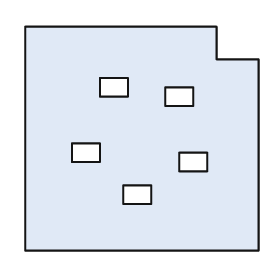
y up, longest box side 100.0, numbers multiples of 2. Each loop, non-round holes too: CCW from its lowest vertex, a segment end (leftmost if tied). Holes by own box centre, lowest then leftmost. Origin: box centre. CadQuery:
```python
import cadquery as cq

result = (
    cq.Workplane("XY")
    .moveTo(-50.0, -48.0)
    .lineTo(50.0, -48.0)
    .lineTo(50.0, 34.0)
    .lineTo(32.0, 34.0)
    .lineTo(32.0, 48.0)
    .lineTo(-50.0, 48.0)
    .close()
    .moveTo(-8.0, -28.0)
    .lineTo(4.0, -28.0)
    .lineTo(4.0, -20.0)
    .lineTo(-8.0, -20.0)
    .close()
    .moveTo(16.0, -14.0)
    .lineTo(28.0, -14.0)
    .lineTo(28.0, -6.0)
    .lineTo(16.0, -6.0)
    .close()
    .moveTo(-30.0, -10.0)
    .lineTo(-18.0, -10.0)
    .lineTo(-18.0, -2.0)
    .lineTo(-30.0, -2.0)
    .close()
    .moveTo(10.0, 14.0)
    .lineTo(22.0, 14.0)
    .lineTo(22.0, 22.0)
    .lineTo(10.0, 22.0)
    .close()
    .moveTo(-18.0, 18.0)
    .lineTo(-6.0, 18.0)
    .lineTo(-6.0, 26.0)
    .lineTo(-18.0, 26.0)
    .close()
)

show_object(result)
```